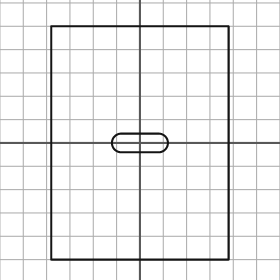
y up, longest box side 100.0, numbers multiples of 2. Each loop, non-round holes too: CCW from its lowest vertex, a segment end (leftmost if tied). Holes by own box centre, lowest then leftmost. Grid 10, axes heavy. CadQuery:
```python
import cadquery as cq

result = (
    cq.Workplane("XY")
    .moveTo(-38.0, -50.0)
    .lineTo(38.0, -50.0)
    .lineTo(38.0, 50.0)
    .lineTo(-38.0, 50.0)
    .close()
    .moveTo(-8.0, -4.0)
    .lineTo(8.0, -4.0)
    .threePointArc((12.0, 0.0), (8.0, 4.0))
    .lineTo(-8.0, 4.0)
    .threePointArc((-12.0, 0.0), (-8.0, -4.0))
    .close()
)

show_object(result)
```